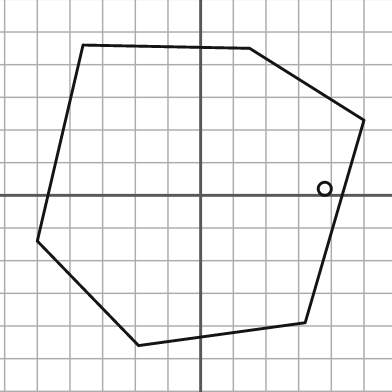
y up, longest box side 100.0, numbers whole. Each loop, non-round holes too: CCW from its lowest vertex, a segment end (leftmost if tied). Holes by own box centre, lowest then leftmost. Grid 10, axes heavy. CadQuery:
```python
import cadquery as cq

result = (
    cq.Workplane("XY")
    .moveTo(-19.0, -46.0)
    .lineTo(32.0, -39.0)
    .lineTo(50.0, 23.0)
    .lineTo(15.0, 45.0)
    .lineTo(-36.0, 46.0)
    .lineTo(-50.0, -14.0)
    .close()
    .moveTo(38.0, 2.0)
    .circle(2.0)
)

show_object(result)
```